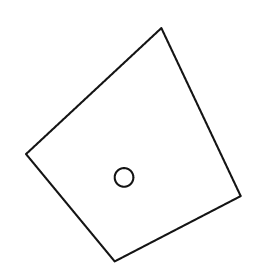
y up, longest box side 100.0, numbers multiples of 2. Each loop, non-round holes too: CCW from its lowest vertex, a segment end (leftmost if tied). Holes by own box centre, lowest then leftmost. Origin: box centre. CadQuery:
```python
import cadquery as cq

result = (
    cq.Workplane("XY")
    .moveTo(-8.0, -50.0)
    .lineTo(46.0, -22.0)
    .lineTo(12.0, 50.0)
    .lineTo(-46.0, -4.0)
    .close()
    .moveTo(-4.0, -14.0)
    .circle(4.0)
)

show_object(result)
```